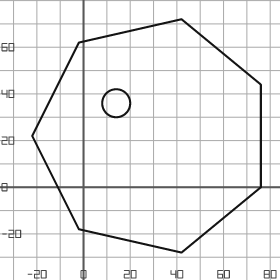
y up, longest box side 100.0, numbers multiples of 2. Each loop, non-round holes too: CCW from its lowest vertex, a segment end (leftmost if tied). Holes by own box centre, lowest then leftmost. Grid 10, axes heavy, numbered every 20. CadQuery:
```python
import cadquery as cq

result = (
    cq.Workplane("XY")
    .moveTo(42.0, -28.0)
    .lineTo(76.0, 0.0)
    .lineTo(76.0, 44.0)
    .lineTo(42.0, 72.0)
    .lineTo(-2.0, 62.0)
    .lineTo(-22.0, 22.0)
    .lineTo(-2.0, -18.0)
    .close()
    .moveTo(14.0, 36.0)
    .circle(6.0)
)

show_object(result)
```